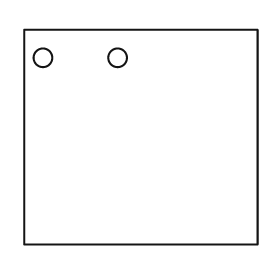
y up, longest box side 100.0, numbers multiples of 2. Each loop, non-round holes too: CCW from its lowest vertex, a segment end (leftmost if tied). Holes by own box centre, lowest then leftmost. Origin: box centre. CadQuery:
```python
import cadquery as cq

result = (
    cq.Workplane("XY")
    .moveTo(-50.0, -46.0)
    .lineTo(50.0, -46.0)
    .lineTo(50.0, 46.0)
    .lineTo(-50.0, 46.0)
    .close()
    .moveTo(-42.0, 34.0)
    .circle(4.0)
    .moveTo(-10.0, 34.0)
    .circle(4.0)
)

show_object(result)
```